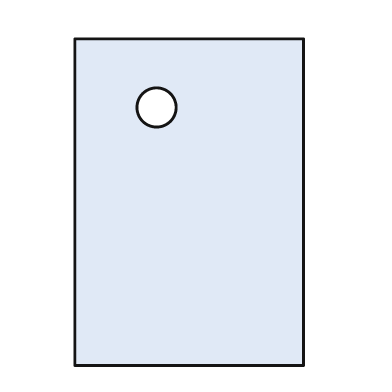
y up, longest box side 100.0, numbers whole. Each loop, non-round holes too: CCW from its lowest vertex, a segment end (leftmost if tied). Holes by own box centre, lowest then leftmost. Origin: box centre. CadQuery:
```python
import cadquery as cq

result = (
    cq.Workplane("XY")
    .moveTo(-35.0, -50.0)
    .lineTo(35.0, -50.0)
    .lineTo(35.0, 50.0)
    .lineTo(-35.0, 50.0)
    .close()
    .moveTo(-10.0, 29.0)
    .circle(6.0)
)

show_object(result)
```